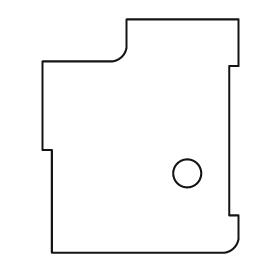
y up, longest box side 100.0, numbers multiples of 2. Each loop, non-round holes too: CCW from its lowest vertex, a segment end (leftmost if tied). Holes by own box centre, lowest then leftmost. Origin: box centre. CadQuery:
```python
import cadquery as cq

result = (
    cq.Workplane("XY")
    .moveTo(-38.0, -50.0)
    .lineTo(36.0, -50.0)
    .threePointArc((40.0, -48.0), (42.0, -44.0))
    .lineTo(42.0, -34.0)
    .lineTo(38.0, -34.0)
    .lineTo(38.0, 30.0)
    .lineTo(42.0, 30.0)
    .lineTo(42.0, 50.0)
    .lineTo(-6.0, 50.0)
    .lineTo(-6.0, 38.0)
    .threePointArc((-8.0, 34.0), (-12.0, 32.0))
    .lineTo(-42.0, 32.0)
    .lineTo(-42.0, -6.0)
    .lineTo(-38.0, -6.0)
    .close()
    .moveTo(20.0, -16.0)
    .circle(6.0)
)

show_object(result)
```